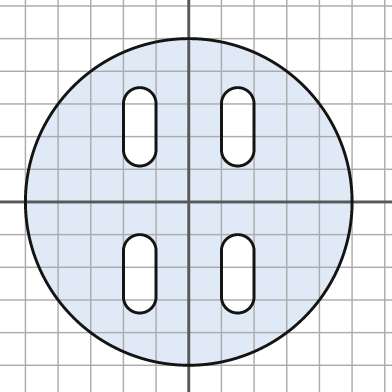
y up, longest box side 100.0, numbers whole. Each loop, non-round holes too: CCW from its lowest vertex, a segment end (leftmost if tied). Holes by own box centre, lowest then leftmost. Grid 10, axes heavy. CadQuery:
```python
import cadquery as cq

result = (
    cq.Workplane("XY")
    .moveTo(0.0, 0.0)
    .circle(50.0)
    .moveTo(-20.0, -29.0)
    .threePointArc((-15.0, -34.0), (-10.0, -29.0))
    .lineTo(-10.0, -15.0)
    .threePointArc((-15.0, -10.0), (-20.0, -15.0))
    .close()
    .moveTo(10.0, -29.0)
    .threePointArc((15.0, -34.0), (20.0, -29.0))
    .lineTo(20.0, -15.0)
    .threePointArc((15.0, -10.0), (10.0, -15.0))
    .close()
    .moveTo(-20.0, 16.0)
    .threePointArc((-15.0, 11.0), (-10.0, 16.0))
    .lineTo(-10.0, 30.0)
    .threePointArc((-15.0, 35.0), (-20.0, 30.0))
    .close()
    .moveTo(10.0, 16.0)
    .threePointArc((15.0, 11.0), (20.0, 16.0))
    .lineTo(20.0, 30.0)
    .threePointArc((15.0, 35.0), (10.0, 30.0))
    .close()
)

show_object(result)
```